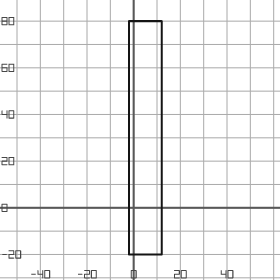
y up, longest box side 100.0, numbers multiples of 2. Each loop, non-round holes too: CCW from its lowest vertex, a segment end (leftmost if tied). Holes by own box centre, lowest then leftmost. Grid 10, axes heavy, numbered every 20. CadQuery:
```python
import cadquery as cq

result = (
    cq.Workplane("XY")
    .moveTo(-2.0, -20.0)
    .lineTo(12.0, -20.0)
    .lineTo(12.0, 80.0)
    .lineTo(-2.0, 80.0)
    .close()
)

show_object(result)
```